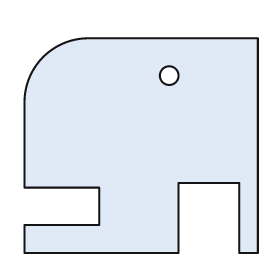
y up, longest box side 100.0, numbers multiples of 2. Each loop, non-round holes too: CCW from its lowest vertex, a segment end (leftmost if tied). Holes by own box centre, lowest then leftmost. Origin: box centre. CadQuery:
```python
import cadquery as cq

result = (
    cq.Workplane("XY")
    .moveTo(-50.0, -46.0)
    .lineTo(16.0, -46.0)
    .lineTo(16.0, -16.0)
    .lineTo(42.0, -16.0)
    .lineTo(42.0, -46.0)
    .lineTo(50.0, -46.0)
    .lineTo(50.0, 46.0)
    .lineTo(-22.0, 46.0)
    .threePointArc((-42.0, 38.0), (-50.0, 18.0))
    .lineTo(-50.0, -18.0)
    .lineTo(-18.0, -18.0)
    .lineTo(-18.0, -34.0)
    .lineTo(-50.0, -34.0)
    .close()
    .moveTo(12.0, 30.0)
    .circle(4.0)
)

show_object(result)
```